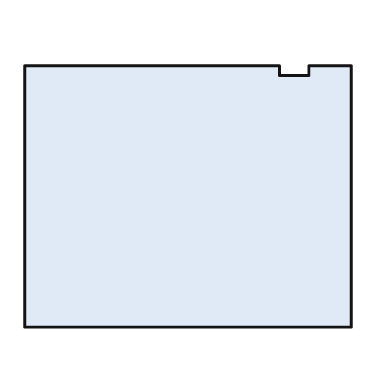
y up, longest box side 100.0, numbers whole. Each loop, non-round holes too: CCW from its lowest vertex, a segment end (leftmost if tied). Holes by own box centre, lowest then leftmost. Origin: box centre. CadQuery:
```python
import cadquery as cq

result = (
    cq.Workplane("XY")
    .moveTo(-50.0, -40.0)
    .lineTo(50.0, -40.0)
    .lineTo(50.0, 40.0)
    .lineTo(37.0, 40.0)
    .lineTo(37.0, 37.0)
    .lineTo(28.0, 37.0)
    .lineTo(28.0, 40.0)
    .lineTo(-50.0, 40.0)
    .close()
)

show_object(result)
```